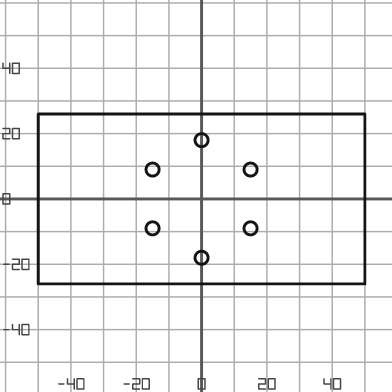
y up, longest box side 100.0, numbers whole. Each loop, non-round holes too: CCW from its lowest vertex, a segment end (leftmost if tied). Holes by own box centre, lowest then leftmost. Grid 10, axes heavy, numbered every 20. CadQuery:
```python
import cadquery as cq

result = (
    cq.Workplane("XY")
    .moveTo(-50.0, -26.0)
    .lineTo(50.0, -26.0)
    .lineTo(50.0, 26.0)
    .lineTo(-50.0, 26.0)
    .close()
    .moveTo(0.0, -18.0)
    .circle(2.0)
    .moveTo(-15.0, -9.0)
    .circle(2.0)
    .moveTo(15.0, -9.0)
    .circle(2.0)
    .moveTo(-15.0, 9.0)
    .circle(2.0)
    .moveTo(15.0, 9.0)
    .circle(2.0)
    .moveTo(0.0, 18.0)
    .circle(2.0)
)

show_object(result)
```